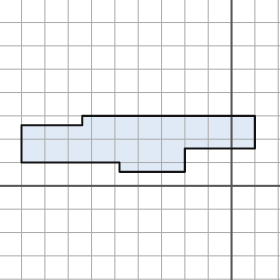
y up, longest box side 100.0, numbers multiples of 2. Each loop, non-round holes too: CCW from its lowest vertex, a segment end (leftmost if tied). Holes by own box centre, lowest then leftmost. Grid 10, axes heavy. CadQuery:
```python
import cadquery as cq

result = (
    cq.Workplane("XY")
    .moveTo(-48.0, 6.0)
    .lineTo(-20.0, 6.0)
    .lineTo(-20.0, 16.0)
    .lineTo(10.0, 16.0)
    .lineTo(10.0, 30.0)
    .lineTo(-64.0, 30.0)
    .lineTo(-64.0, 26.0)
    .lineTo(-90.0, 26.0)
    .lineTo(-90.0, 10.0)
    .lineTo(-48.0, 10.0)
    .close()
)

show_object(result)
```